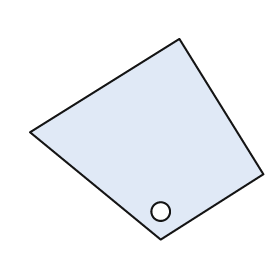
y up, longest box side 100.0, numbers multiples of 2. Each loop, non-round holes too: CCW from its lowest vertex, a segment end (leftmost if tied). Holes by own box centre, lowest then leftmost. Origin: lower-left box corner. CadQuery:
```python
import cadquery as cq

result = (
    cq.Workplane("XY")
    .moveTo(56.0, 0.0)
    .lineTo(100.0, 28.0)
    .lineTo(64.0, 86.0)
    .lineTo(0.0, 46.0)
    .close()
    .moveTo(56.0, 12.0)
    .circle(4.0)
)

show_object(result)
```